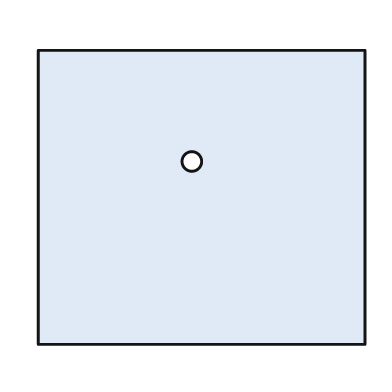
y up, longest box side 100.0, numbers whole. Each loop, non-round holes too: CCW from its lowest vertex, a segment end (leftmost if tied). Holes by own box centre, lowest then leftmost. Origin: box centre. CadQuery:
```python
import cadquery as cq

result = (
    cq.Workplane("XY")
    .moveTo(-50.0, -45.0)
    .lineTo(50.0, -45.0)
    .lineTo(50.0, 45.0)
    .lineTo(-50.0, 45.0)
    .close()
    .moveTo(-3.0, 11.0)
    .circle(3.0)
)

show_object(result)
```